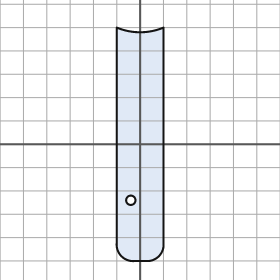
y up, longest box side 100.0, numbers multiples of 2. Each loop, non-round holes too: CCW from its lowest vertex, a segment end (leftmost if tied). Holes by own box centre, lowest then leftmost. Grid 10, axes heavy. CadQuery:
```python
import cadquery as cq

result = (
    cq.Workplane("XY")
    .moveTo(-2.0, -50.0)
    .lineTo(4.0, -50.0)
    .threePointArc((8.0, -48.0), (10.0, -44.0))
    .lineTo(10.0, 50.0)
    .threePointArc((0.0, 48.0), (-10.0, 50.0))
    .lineTo(-10.0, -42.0)
    .threePointArc((-8.0, -48.0), (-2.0, -50.0))
    .close()
    .moveTo(-4.0, -24.0)
    .circle(2.0)
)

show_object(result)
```